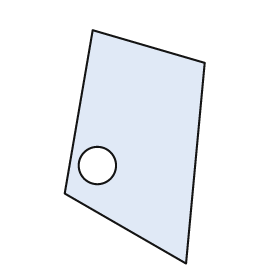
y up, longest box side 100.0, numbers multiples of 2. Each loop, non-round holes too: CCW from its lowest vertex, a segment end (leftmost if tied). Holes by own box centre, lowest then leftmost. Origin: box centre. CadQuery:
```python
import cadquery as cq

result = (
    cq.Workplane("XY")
    .moveTo(22.0, -50.0)
    .lineTo(30.0, 36.0)
    .lineTo(-18.0, 50.0)
    .lineTo(-30.0, -20.0)
    .close()
    .moveTo(-16.0, -8.0)
    .circle(8.0)
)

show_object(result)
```